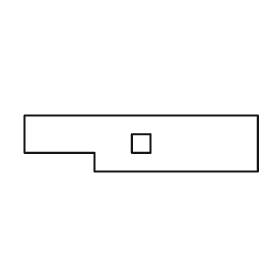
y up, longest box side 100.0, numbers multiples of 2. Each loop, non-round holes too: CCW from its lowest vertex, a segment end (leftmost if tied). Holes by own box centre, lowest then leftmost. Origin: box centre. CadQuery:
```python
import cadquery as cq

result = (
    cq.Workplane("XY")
    .moveTo(-20.0, -12.0)
    .lineTo(50.0, -12.0)
    .lineTo(50.0, 12.0)
    .lineTo(-50.0, 12.0)
    .lineTo(-50.0, -4.0)
    .lineTo(-20.0, -4.0)
    .close()
    .moveTo(-4.0, -4.0)
    .lineTo(4.0, -4.0)
    .lineTo(4.0, 4.0)
    .lineTo(-4.0, 4.0)
    .close()
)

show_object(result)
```